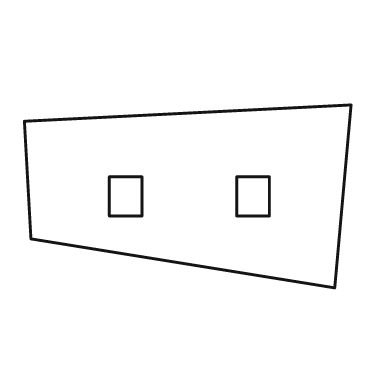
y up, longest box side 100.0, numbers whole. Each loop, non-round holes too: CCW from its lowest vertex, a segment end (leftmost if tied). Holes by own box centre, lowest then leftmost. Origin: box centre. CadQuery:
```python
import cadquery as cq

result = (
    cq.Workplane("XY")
    .moveTo(45.0, -28.0)
    .lineTo(50.0, 28.0)
    .lineTo(-50.0, 23.0)
    .lineTo(-48.0, -13.0)
    .close()
    .moveTo(-24.0, -6.0)
    .lineTo(-14.0, -6.0)
    .lineTo(-14.0, 6.0)
    .lineTo(-24.0, 6.0)
    .close()
    .moveTo(15.0, -6.0)
    .lineTo(25.0, -6.0)
    .lineTo(25.0, 6.0)
    .lineTo(15.0, 6.0)
    .close()
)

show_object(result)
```